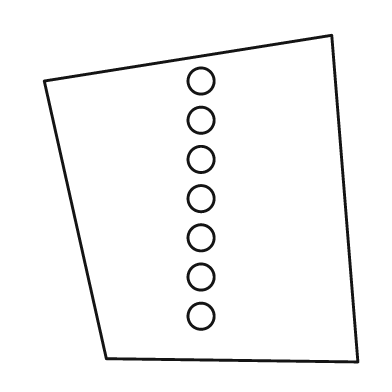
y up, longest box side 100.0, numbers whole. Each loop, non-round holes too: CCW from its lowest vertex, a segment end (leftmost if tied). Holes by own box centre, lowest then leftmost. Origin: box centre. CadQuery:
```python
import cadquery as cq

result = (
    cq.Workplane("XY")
    .moveTo(48.0, -50.0)
    .lineTo(40.0, 50.0)
    .lineTo(-48.0, 36.0)
    .lineTo(-29.0, -49.0)
    .close()
    .moveTo(0.0, -36.0)
    .circle(4.0)
    .moveTo(0.0, -24.0)
    .circle(4.0)
    .moveTo(0.0, -12.0)
    .circle(4.0)
    .moveTo(0.0, 0.0)
    .circle(4.0)
    .moveTo(0.0, 12.0)
    .circle(4.0)
    .moveTo(0.0, 24.0)
    .circle(4.0)
    .moveTo(0.0, 36.0)
    .circle(4.0)
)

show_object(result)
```